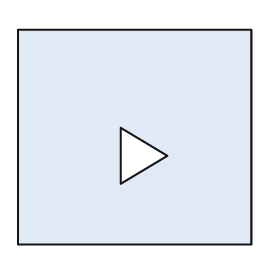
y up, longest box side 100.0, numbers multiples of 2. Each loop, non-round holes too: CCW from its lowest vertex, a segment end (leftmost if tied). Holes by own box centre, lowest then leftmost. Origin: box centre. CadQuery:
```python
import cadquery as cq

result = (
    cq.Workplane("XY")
    .moveTo(-50.0, -46.0)
    .lineTo(50.0, -46.0)
    .lineTo(50.0, 46.0)
    .lineTo(-50.0, 46.0)
    .close()
    .moveTo(-6.0, -20.0)
    .lineTo(14.0, -8.0)
    .lineTo(-6.0, 4.0)
    .close()
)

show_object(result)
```